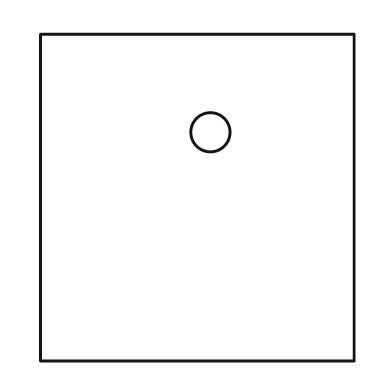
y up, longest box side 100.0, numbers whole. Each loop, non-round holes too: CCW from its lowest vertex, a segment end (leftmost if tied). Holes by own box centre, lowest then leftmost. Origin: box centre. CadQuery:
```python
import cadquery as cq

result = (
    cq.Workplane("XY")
    .moveTo(-48.0, -50.0)
    .lineTo(48.0, -50.0)
    .lineTo(48.0, 50.0)
    .lineTo(-48.0, 50.0)
    .close()
    .moveTo(4.0, 20.0)
    .circle(6.0)
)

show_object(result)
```